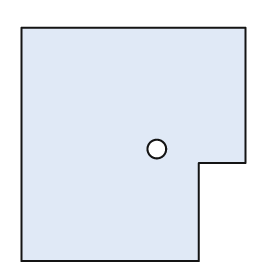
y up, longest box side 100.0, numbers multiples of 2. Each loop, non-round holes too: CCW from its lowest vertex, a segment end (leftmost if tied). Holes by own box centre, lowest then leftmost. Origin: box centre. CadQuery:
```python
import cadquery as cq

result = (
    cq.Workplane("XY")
    .moveTo(-48.0, -50.0)
    .lineTo(28.0, -50.0)
    .lineTo(28.0, -8.0)
    .lineTo(48.0, -8.0)
    .lineTo(48.0, 50.0)
    .lineTo(-48.0, 50.0)
    .close()
    .moveTo(10.0, -2.0)
    .circle(4.0)
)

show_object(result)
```